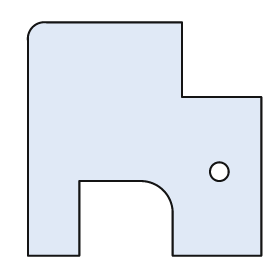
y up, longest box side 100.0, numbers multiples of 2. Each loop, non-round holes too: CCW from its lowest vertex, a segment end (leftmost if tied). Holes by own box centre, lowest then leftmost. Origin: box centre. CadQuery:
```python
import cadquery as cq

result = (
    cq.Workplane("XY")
    .moveTo(-50.0, -50.0)
    .lineTo(-28.0, -50.0)
    .lineTo(-28.0, -18.0)
    .lineTo(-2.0, -18.0)
    .threePointArc((8.0, -22.0), (12.0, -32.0))
    .lineTo(12.0, -50.0)
    .lineTo(50.0, -50.0)
    .lineTo(50.0, 18.0)
    .lineTo(16.0, 18.0)
    .lineTo(16.0, 50.0)
    .lineTo(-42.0, 50.0)
    .threePointArc((-48.0, 48.0), (-50.0, 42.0))
    .close()
    .moveTo(32.0, -14.0)
    .circle(4.0)
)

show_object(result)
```